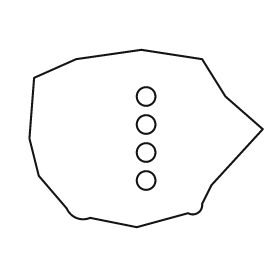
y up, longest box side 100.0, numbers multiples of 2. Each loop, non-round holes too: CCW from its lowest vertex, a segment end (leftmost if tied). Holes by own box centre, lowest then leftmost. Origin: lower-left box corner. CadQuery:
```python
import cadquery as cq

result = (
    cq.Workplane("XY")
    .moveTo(46.0, 0.0)
    .lineTo(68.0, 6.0)
    .threePointArc((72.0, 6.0), (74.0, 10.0))
    .lineTo(78.0, 18.0)
    .lineTo(100.0, 42.0)
    .lineTo(84.0, 56.0)
    .lineTo(74.0, 72.0)
    .lineTo(48.0, 76.0)
    .lineTo(20.0, 72.0)
    .lineTo(2.0, 64.0)
    .lineTo(0.0, 38.0)
    .lineTo(4.0, 22.0)
    .lineTo(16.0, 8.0)
    .threePointArc((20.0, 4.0), (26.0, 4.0))
    .close()
    .moveTo(50.0, 20.0)
    .circle(4.0)
    .moveTo(50.0, 32.0)
    .circle(4.0)
    .moveTo(50.0, 44.0)
    .circle(4.0)
    .moveTo(50.0, 56.0)
    .circle(4.0)
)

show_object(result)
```